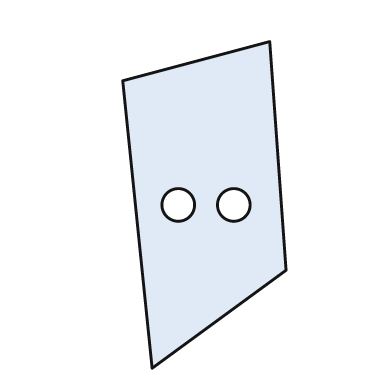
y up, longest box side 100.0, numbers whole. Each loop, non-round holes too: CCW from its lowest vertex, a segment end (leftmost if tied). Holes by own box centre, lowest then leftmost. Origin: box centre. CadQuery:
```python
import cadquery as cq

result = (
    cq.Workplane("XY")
    .moveTo(-16.0, -50.0)
    .lineTo(25.0, -20.0)
    .lineTo(20.0, 50.0)
    .lineTo(-25.0, 38.0)
    .close()
    .moveTo(-8.0, 0.0)
    .circle(5.0)
    .moveTo(9.0, 0.0)
    .circle(5.0)
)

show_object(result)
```